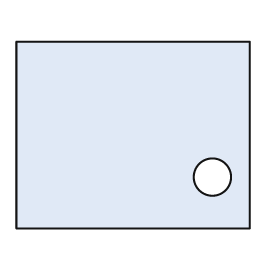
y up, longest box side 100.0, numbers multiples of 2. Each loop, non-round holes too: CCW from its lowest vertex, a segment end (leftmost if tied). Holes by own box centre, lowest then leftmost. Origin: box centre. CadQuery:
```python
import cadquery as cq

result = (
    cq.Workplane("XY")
    .moveTo(-50.0, -40.0)
    .lineTo(50.0, -40.0)
    .lineTo(50.0, 40.0)
    .lineTo(-50.0, 40.0)
    .close()
    .moveTo(34.0, -18.0)
    .circle(8.0)
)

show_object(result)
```